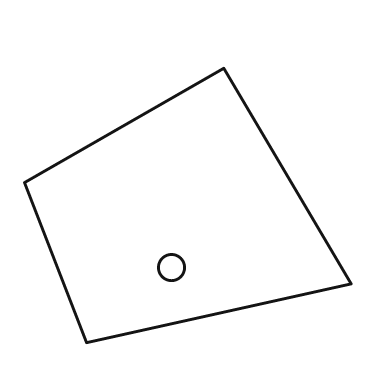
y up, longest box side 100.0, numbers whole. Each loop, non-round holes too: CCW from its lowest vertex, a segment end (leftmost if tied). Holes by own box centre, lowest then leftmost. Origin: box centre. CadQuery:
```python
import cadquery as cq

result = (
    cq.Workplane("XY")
    .moveTo(-31.0, -42.0)
    .lineTo(50.0, -24.0)
    .lineTo(11.0, 42.0)
    .lineTo(-50.0, 7.0)
    .close()
    .moveTo(-5.0, -19.0)
    .circle(4.0)
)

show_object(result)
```